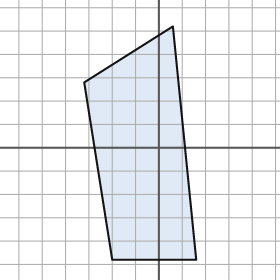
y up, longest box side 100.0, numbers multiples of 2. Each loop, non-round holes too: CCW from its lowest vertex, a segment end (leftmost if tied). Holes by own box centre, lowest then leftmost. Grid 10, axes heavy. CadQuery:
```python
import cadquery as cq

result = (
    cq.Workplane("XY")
    .moveTo(-20.0, -48.0)
    .lineTo(16.0, -48.0)
    .lineTo(6.0, 52.0)
    .lineTo(-32.0, 28.0)
    .close()
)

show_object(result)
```